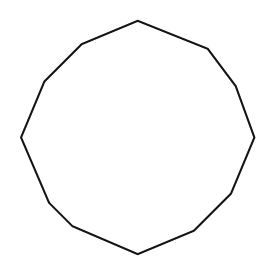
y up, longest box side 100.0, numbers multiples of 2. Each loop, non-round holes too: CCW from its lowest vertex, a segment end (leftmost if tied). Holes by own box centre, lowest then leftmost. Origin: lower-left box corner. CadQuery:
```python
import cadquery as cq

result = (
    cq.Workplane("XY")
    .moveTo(50.0, 0.0)
    .lineTo(74.0, 10.0)
    .lineTo(90.0, 26.0)
    .lineTo(100.0, 50.0)
    .lineTo(92.0, 72.0)
    .lineTo(80.0, 88.0)
    .lineTo(50.0, 100.0)
    .lineTo(26.0, 90.0)
    .lineTo(10.0, 74.0)
    .lineTo(0.0, 50.0)
    .lineTo(12.0, 22.0)
    .lineTo(22.0, 12.0)
    .close()
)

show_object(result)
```